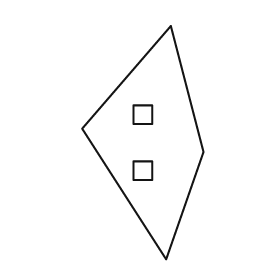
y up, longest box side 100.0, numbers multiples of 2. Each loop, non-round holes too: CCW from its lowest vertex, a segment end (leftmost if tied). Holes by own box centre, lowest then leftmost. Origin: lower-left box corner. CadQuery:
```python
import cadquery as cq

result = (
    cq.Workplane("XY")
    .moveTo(36.0, 0.0)
    .lineTo(52.0, 46.0)
    .lineTo(38.0, 100.0)
    .lineTo(0.0, 56.0)
    .close()
    .moveTo(22.0, 34.0)
    .lineTo(30.0, 34.0)
    .lineTo(30.0, 42.0)
    .lineTo(22.0, 42.0)
    .close()
    .moveTo(22.0, 58.0)
    .lineTo(30.0, 58.0)
    .lineTo(30.0, 66.0)
    .lineTo(22.0, 66.0)
    .close()
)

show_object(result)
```